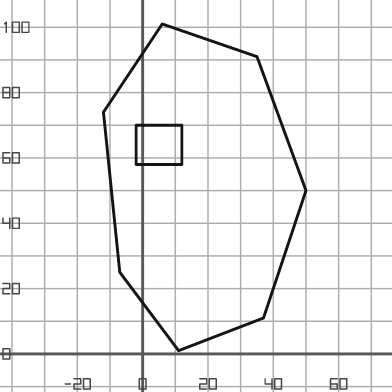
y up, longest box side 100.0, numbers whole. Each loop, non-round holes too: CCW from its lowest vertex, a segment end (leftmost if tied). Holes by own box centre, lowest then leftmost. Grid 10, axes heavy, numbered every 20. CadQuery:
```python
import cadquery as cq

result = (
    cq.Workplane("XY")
    .moveTo(11.0, 1.0)
    .lineTo(37.0, 11.0)
    .lineTo(50.0, 50.0)
    .lineTo(35.0, 91.0)
    .lineTo(6.0, 101.0)
    .lineTo(-12.0, 74.0)
    .lineTo(-7.0, 25.0)
    .close()
    .moveTo(-2.0, 58.0)
    .lineTo(12.0, 58.0)
    .lineTo(12.0, 70.0)
    .lineTo(-2.0, 70.0)
    .close()
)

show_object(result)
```